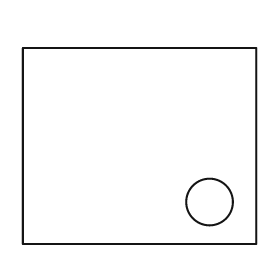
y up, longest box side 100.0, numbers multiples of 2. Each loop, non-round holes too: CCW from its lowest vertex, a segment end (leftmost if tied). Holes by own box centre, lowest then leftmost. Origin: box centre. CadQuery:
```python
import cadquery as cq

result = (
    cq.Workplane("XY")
    .moveTo(-50.0, -42.0)
    .lineTo(50.0, -42.0)
    .lineTo(50.0, 42.0)
    .lineTo(-50.0, 42.0)
    .close()
    .moveTo(30.0, -24.0)
    .circle(10.0)
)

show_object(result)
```